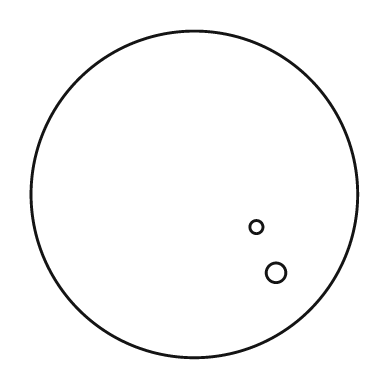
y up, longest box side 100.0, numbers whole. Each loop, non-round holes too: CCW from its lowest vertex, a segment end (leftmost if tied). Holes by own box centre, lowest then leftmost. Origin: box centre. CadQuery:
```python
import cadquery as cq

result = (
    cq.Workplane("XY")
    .moveTo(0.0, 0.0)
    .circle(50.0)
    .moveTo(25.0, -24.0)
    .circle(3.0)
    .moveTo(19.0, -10.0)
    .circle(2.0)
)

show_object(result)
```